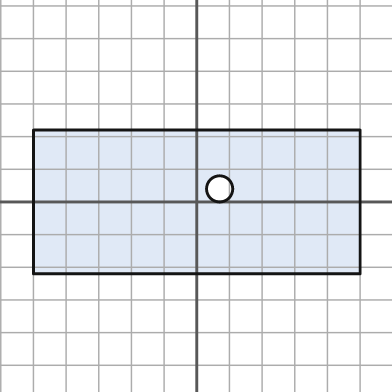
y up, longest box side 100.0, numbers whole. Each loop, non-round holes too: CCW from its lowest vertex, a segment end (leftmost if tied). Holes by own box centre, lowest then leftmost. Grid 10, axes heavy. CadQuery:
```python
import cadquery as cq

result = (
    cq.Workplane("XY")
    .moveTo(-50.0, -22.0)
    .lineTo(50.0, -22.0)
    .lineTo(50.0, 22.0)
    .lineTo(-50.0, 22.0)
    .close()
    .moveTo(7.0, 4.0)
    .circle(4.0)
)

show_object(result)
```